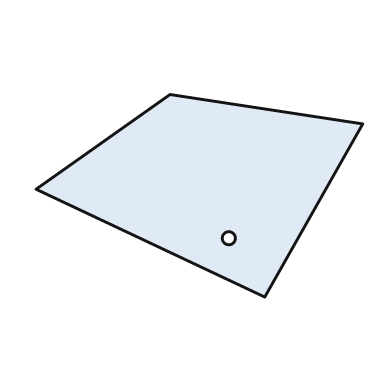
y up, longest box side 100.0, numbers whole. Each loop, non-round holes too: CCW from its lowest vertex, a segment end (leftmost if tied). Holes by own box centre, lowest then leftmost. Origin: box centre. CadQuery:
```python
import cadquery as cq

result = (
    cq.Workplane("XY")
    .moveTo(20.0, -31.0)
    .lineTo(50.0, 22.0)
    .lineTo(-9.0, 31.0)
    .lineTo(-50.0, 2.0)
    .close()
    .moveTo(9.0, -13.0)
    .circle(2.0)
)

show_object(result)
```